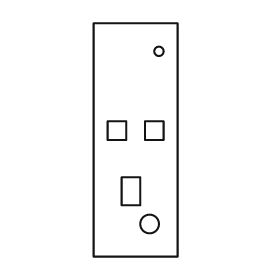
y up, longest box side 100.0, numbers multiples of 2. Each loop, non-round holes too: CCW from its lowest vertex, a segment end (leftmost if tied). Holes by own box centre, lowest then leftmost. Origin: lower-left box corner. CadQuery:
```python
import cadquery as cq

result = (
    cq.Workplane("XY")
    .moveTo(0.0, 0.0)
    .lineTo(36.0, 0.0)
    .lineTo(36.0, 100.0)
    .lineTo(0.0, 100.0)
    .close()
    .moveTo(24.0, 14.0)
    .circle(4.0)
    .moveTo(12.0, 22.0)
    .lineTo(20.0, 22.0)
    .lineTo(20.0, 34.0)
    .lineTo(12.0, 34.0)
    .close()
    .moveTo(6.0, 50.0)
    .lineTo(14.0, 50.0)
    .lineTo(14.0, 58.0)
    .lineTo(6.0, 58.0)
    .close()
    .moveTo(22.0, 50.0)
    .lineTo(30.0, 50.0)
    .lineTo(30.0, 58.0)
    .lineTo(22.0, 58.0)
    .close()
    .moveTo(28.0, 88.0)
    .circle(2.0)
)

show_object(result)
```